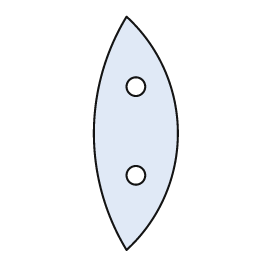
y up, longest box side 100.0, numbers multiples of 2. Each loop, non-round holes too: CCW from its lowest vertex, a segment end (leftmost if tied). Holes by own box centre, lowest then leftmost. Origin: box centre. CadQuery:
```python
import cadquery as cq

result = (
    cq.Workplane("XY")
    .moveTo(-4.0, -50.0)
    .threePointArc((18.0, 0.0), (-4.0, 50.0))
    .threePointArc((-18.0, 0.0), (-4.0, -50.0))
    .close()
    .moveTo(0.0, -18.0)
    .circle(4.0)
    .moveTo(0.0, 20.0)
    .circle(4.0)
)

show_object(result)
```